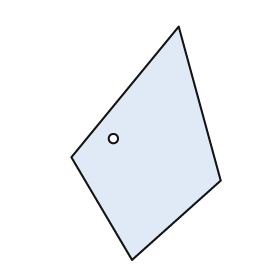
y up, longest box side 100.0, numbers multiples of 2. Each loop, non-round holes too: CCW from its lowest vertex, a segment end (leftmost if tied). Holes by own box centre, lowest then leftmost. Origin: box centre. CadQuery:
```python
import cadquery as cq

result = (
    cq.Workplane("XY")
    .moveTo(-6.0, -50.0)
    .lineTo(32.0, -16.0)
    .lineTo(14.0, 50.0)
    .lineTo(-32.0, -6.0)
    .close()
    .moveTo(-14.0, 2.0)
    .circle(2.0)
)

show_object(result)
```